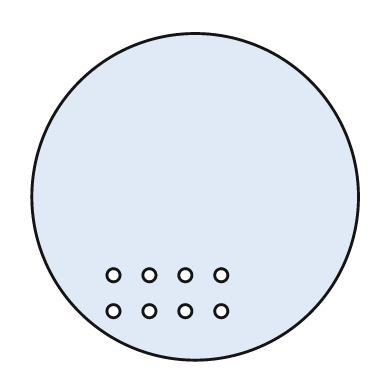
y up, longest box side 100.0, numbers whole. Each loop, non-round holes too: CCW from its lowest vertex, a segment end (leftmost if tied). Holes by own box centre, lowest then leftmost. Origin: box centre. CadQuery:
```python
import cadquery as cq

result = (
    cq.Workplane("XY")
    .moveTo(0.0, 0.0)
    .circle(50.0)
    .moveTo(-25.0, -35.0)
    .circle(2.0)
    .moveTo(-14.0, -35.0)
    .circle(2.0)
    .moveTo(-3.0, -35.0)
    .circle(2.0)
    .moveTo(8.0, -35.0)
    .circle(2.0)
    .moveTo(-25.0, -24.0)
    .circle(2.0)
    .moveTo(-14.0, -24.0)
    .circle(2.0)
    .moveTo(-3.0, -24.0)
    .circle(2.0)
    .moveTo(8.0, -24.0)
    .circle(2.0)
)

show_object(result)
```